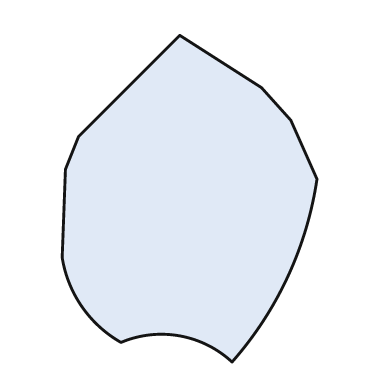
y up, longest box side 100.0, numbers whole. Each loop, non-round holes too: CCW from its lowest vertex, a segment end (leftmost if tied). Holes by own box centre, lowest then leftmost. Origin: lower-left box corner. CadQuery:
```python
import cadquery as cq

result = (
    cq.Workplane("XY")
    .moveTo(52.0, 0.0)
    .threePointArc((69.0, 26.0), (78.0, 56.0))
    .lineTo(70.0, 74.0)
    .lineTo(61.0, 84.0)
    .lineTo(36.0, 100.0)
    .lineTo(5.0, 69.0)
    .lineTo(1.0, 59.0)
    .lineTo(0.0, 32.0)
    .threePointArc((6.0, 17.0), (18.0, 6.0))
    .threePointArc((36.0, 8.0), (52.0, 0.0))
    .close()
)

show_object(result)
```